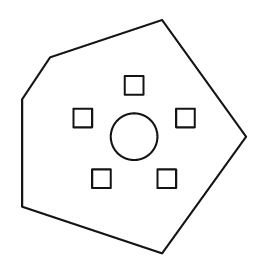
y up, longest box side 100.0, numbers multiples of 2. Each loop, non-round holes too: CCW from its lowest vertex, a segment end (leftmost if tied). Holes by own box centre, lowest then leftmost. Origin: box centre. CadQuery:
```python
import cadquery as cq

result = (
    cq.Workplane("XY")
    .moveTo(12.0, -50.0)
    .lineTo(48.0, 0.0)
    .lineTo(12.0, 50.0)
    .lineTo(-36.0, 34.0)
    .lineTo(-48.0, 16.0)
    .lineTo(-48.0, -30.0)
    .close()
    .moveTo(-18.0, -22.0)
    .lineTo(-10.0, -22.0)
    .lineTo(-10.0, -14.0)
    .lineTo(-18.0, -14.0)
    .close()
    .moveTo(10.0, -22.0)
    .lineTo(18.0, -22.0)
    .lineTo(18.0, -14.0)
    .lineTo(10.0, -14.0)
    .close()
    .moveTo(0.0, 0.0)
    .circle(10.0)
    .moveTo(-26.0, 4.0)
    .lineTo(-18.0, 4.0)
    .lineTo(-18.0, 12.0)
    .lineTo(-26.0, 12.0)
    .close()
    .moveTo(18.0, 4.0)
    .lineTo(26.0, 4.0)
    .lineTo(26.0, 12.0)
    .lineTo(18.0, 12.0)
    .close()
    .moveTo(-4.0, 18.0)
    .lineTo(4.0, 18.0)
    .lineTo(4.0, 26.0)
    .lineTo(-4.0, 26.0)
    .close()
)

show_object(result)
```